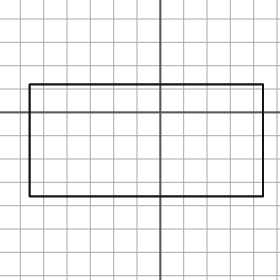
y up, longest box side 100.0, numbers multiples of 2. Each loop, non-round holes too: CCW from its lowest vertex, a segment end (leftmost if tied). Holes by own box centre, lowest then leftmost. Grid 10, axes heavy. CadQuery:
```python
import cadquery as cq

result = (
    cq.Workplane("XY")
    .moveTo(-56.0, -36.0)
    .lineTo(44.0, -36.0)
    .lineTo(44.0, 12.0)
    .lineTo(-56.0, 12.0)
    .close()
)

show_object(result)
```